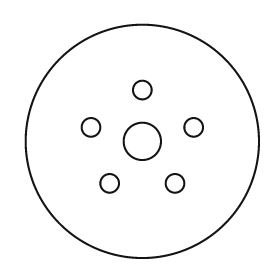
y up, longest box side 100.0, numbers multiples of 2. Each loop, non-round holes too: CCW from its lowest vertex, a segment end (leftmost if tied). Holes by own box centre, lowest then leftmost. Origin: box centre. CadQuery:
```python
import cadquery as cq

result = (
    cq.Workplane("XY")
    .moveTo(0.0, 0.0)
    .circle(50.0)
    .moveTo(-14.0, -18.0)
    .circle(4.0)
    .moveTo(14.0, -18.0)
    .circle(4.0)
    .moveTo(0.0, 0.0)
    .circle(8.0)
    .moveTo(-22.0, 6.0)
    .circle(4.0)
    .moveTo(22.0, 6.0)
    .circle(4.0)
    .moveTo(0.0, 22.0)
    .circle(4.0)
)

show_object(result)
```